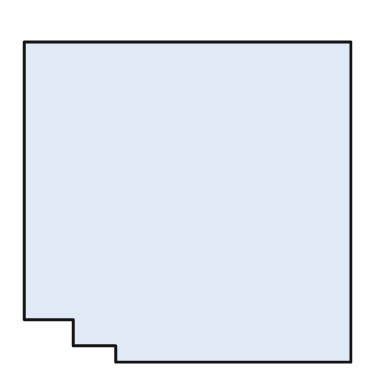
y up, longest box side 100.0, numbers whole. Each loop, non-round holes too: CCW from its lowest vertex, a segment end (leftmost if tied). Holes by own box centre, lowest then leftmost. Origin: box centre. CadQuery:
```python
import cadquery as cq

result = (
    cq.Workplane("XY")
    .moveTo(-22.0, -49.0)
    .lineTo(50.0, -49.0)
    .lineTo(50.0, 49.0)
    .lineTo(-50.0, 49.0)
    .lineTo(-50.0, -36.0)
    .lineTo(-35.0, -36.0)
    .lineTo(-35.0, -44.0)
    .lineTo(-22.0, -44.0)
    .close()
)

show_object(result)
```